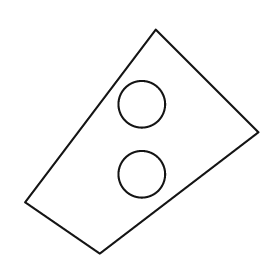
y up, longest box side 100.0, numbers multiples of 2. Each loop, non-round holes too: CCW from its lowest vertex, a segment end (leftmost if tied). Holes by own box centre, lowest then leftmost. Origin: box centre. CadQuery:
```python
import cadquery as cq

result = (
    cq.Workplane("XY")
    .moveTo(-18.0, -48.0)
    .lineTo(50.0, 4.0)
    .lineTo(6.0, 48.0)
    .lineTo(-50.0, -26.0)
    .close()
    .moveTo(0.0, -14.0)
    .circle(10.0)
    .moveTo(0.0, 16.0)
    .circle(10.0)
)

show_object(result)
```